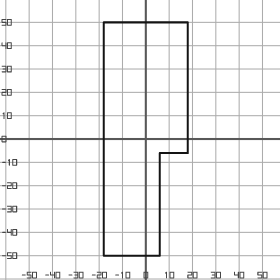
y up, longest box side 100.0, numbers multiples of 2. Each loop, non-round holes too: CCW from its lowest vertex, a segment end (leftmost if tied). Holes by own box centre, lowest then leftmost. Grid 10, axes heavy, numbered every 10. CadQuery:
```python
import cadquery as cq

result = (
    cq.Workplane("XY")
    .moveTo(-18.0, -50.0)
    .lineTo(6.0, -50.0)
    .lineTo(6.0, -6.0)
    .lineTo(18.0, -6.0)
    .lineTo(18.0, 50.0)
    .lineTo(-18.0, 50.0)
    .close()
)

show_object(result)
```